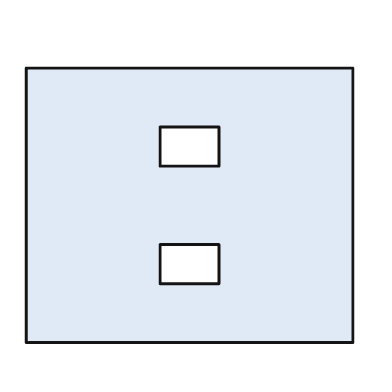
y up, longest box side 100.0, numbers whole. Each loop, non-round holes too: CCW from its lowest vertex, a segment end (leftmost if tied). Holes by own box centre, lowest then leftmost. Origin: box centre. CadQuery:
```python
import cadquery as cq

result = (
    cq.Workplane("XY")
    .moveTo(-50.0, -42.0)
    .lineTo(50.0, -42.0)
    .lineTo(50.0, 42.0)
    .lineTo(-50.0, 42.0)
    .close()
    .moveTo(-9.0, -24.0)
    .lineTo(9.0, -24.0)
    .lineTo(9.0, -12.0)
    .lineTo(-9.0, -12.0)
    .close()
    .moveTo(-9.0, 12.0)
    .lineTo(9.0, 12.0)
    .lineTo(9.0, 24.0)
    .lineTo(-9.0, 24.0)
    .close()
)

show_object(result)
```